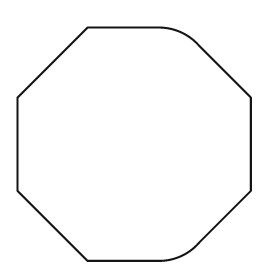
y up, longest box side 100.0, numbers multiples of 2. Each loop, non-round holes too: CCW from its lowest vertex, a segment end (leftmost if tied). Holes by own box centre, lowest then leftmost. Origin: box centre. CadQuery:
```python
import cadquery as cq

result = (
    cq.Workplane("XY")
    .moveTo(-20.0, -50.0)
    .lineTo(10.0, -50.0)
    .threePointArc((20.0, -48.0), (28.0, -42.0))
    .lineTo(50.0, -20.0)
    .lineTo(50.0, 20.0)
    .lineTo(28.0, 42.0)
    .threePointArc((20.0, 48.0), (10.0, 50.0))
    .lineTo(-20.0, 50.0)
    .lineTo(-50.0, 20.0)
    .lineTo(-50.0, -20.0)
    .close()
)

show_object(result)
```